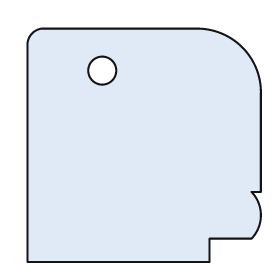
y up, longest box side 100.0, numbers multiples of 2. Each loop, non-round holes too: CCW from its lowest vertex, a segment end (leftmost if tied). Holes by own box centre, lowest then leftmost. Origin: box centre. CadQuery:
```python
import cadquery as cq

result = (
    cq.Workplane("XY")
    .moveTo(-50.0, -50.0)
    .lineTo(28.0, -50.0)
    .lineTo(28.0, -40.0)
    .lineTo(46.0, -40.0)
    .threePointArc((50.0, -30.0), (46.0, -20.0))
    .lineTo(50.0, -20.0)
    .lineTo(50.0, 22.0)
    .threePointArc((42.0, 42.0), (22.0, 50.0))
    .lineTo(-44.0, 50.0)
    .threePointArc((-48.0, 48.0), (-50.0, 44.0))
    .close()
    .moveTo(-18.0, 32.0)
    .circle(6.0)
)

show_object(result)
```